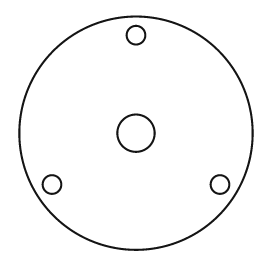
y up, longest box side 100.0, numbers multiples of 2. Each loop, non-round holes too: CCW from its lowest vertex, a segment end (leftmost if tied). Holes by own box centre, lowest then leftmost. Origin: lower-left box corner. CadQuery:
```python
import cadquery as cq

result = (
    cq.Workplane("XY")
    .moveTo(50.0, 50.0)
    .circle(50.0)
    .moveTo(14.0, 28.0)
    .circle(4.0)
    .moveTo(86.0, 28.0)
    .circle(4.0)
    .moveTo(50.0, 50.0)
    .circle(8.0)
    .moveTo(50.0, 92.0)
    .circle(4.0)
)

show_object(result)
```